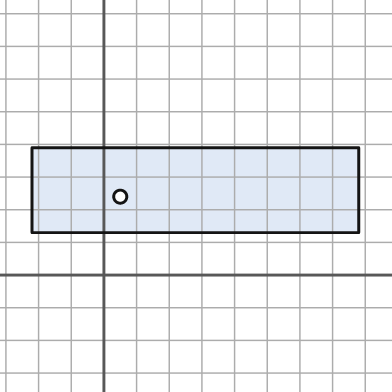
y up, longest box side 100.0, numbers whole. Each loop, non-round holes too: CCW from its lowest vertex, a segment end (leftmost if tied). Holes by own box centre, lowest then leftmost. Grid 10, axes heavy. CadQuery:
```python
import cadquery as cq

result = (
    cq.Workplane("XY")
    .moveTo(-22.0, 13.0)
    .lineTo(78.0, 13.0)
    .lineTo(78.0, 39.0)
    .lineTo(-22.0, 39.0)
    .close()
    .moveTo(5.0, 24.0)
    .circle(2.0)
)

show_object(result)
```